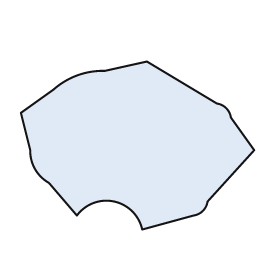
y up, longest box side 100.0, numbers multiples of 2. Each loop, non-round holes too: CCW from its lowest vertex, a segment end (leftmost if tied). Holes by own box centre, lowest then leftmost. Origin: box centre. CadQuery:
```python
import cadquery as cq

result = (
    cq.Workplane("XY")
    .moveTo(2.0, -36.0)
    .lineTo(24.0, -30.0)
    .threePointArc((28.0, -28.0), (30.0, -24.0))
    .lineTo(50.0, -2.0)
    .lineTo(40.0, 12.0)
    .threePointArc((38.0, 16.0), (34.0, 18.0))
    .lineTo(4.0, 36.0)
    .lineTo(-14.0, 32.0)
    .threePointArc((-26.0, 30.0), (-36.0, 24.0))
    .lineTo(-50.0, 14.0)
    .lineTo(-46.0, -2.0)
    .threePointArc((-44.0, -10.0), (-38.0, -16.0))
    .lineTo(-26.0, -30.0)
    .threePointArc((-10.0, -24.0), (2.0, -36.0))
    .close()
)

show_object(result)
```